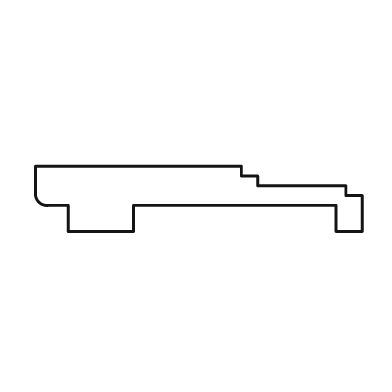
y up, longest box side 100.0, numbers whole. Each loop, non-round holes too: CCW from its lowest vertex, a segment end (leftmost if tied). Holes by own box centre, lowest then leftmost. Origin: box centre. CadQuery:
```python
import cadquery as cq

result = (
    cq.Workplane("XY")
    .moveTo(-40.0, -10.0)
    .lineTo(-20.0, -10.0)
    .lineTo(-20.0, -2.0)
    .lineTo(42.0, -2.0)
    .lineTo(42.0, -10.0)
    .lineTo(50.0, -10.0)
    .lineTo(50.0, 1.0)
    .lineTo(45.0, 1.0)
    .lineTo(45.0, 4.0)
    .lineTo(18.0, 4.0)
    .lineTo(18.0, 7.0)
    .lineTo(13.0, 7.0)
    .lineTo(13.0, 10.0)
    .lineTo(-50.0, 10.0)
    .lineTo(-50.0, 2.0)
    .threePointArc((-49.0, -1.0), (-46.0, -2.0))
    .lineTo(-40.0, -2.0)
    .close()
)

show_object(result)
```